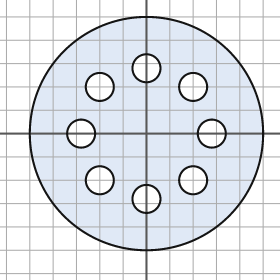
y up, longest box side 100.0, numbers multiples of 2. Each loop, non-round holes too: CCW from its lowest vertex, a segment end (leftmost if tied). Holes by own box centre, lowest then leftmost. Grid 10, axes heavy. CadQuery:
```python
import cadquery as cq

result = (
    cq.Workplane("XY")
    .moveTo(0.0, 0.0)
    .circle(50.0)
    .moveTo(0.0, -28.0)
    .circle(6.0)
    .moveTo(-20.0, -20.0)
    .circle(6.0)
    .moveTo(20.0, -20.0)
    .circle(6.0)
    .moveTo(-28.0, 0.0)
    .circle(6.0)
    .moveTo(28.0, 0.0)
    .circle(6.0)
    .moveTo(-20.0, 20.0)
    .circle(6.0)
    .moveTo(20.0, 20.0)
    .circle(6.0)
    .moveTo(0.0, 28.0)
    .circle(6.0)
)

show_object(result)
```